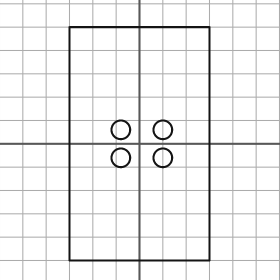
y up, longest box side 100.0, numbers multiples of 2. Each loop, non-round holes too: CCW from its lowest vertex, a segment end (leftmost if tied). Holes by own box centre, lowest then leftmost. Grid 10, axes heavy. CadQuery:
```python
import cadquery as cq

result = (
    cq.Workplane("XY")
    .moveTo(-30.0, -50.0)
    .lineTo(30.0, -50.0)
    .lineTo(30.0, 50.0)
    .lineTo(-30.0, 50.0)
    .close()
    .moveTo(-8.0, -6.0)
    .circle(4.0)
    .moveTo(10.0, -6.0)
    .circle(4.0)
    .moveTo(-8.0, 6.0)
    .circle(4.0)
    .moveTo(10.0, 6.0)
    .circle(4.0)
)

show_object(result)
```